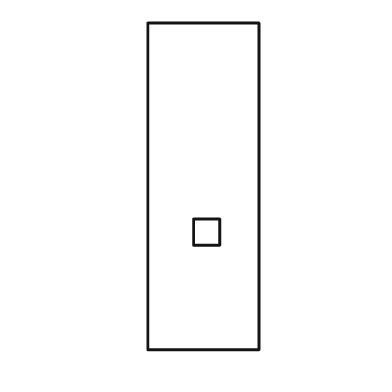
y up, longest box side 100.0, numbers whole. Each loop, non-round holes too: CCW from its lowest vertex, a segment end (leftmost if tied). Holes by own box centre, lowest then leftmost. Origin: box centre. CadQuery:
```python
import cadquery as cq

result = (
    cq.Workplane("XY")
    .moveTo(-17.0, -50.0)
    .lineTo(17.0, -50.0)
    .lineTo(17.0, 50.0)
    .lineTo(-17.0, 50.0)
    .close()
    .moveTo(-3.0, -18.0)
    .lineTo(5.0, -18.0)
    .lineTo(5.0, -10.0)
    .lineTo(-3.0, -10.0)
    .close()
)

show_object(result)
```